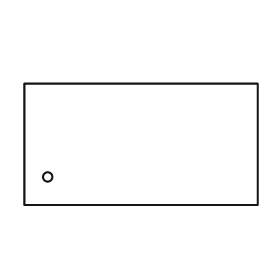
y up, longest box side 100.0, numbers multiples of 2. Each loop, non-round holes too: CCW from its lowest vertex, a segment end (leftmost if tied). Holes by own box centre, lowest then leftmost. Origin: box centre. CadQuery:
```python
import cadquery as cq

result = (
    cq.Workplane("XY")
    .moveTo(-50.0, -26.0)
    .lineTo(50.0, -26.0)
    .lineTo(50.0, 26.0)
    .lineTo(-50.0, 26.0)
    .close()
    .moveTo(-40.0, -14.0)
    .circle(2.0)
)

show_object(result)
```